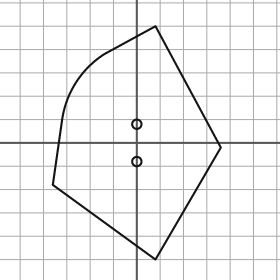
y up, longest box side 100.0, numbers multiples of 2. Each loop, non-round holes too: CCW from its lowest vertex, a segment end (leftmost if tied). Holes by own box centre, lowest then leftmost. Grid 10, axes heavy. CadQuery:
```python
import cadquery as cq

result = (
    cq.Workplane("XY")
    .moveTo(8.0, -50.0)
    .lineTo(36.0, -2.0)
    .lineTo(8.0, 50.0)
    .lineTo(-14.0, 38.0)
    .threePointArc((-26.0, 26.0), (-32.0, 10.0))
    .lineTo(-36.0, -18.0)
    .close()
    .moveTo(0.0, -8.0)
    .circle(2.0)
    .moveTo(0.0, 8.0)
    .circle(2.0)
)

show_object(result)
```